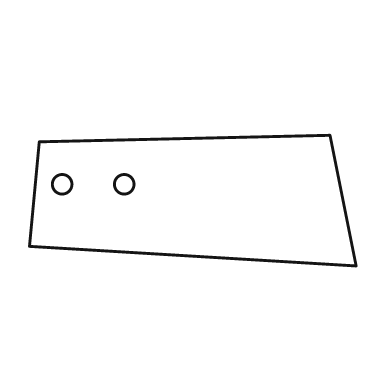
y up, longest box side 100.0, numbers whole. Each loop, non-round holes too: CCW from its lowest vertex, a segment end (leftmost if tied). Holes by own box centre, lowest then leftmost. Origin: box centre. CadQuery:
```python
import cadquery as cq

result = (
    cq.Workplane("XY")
    .moveTo(50.0, -20.0)
    .lineTo(42.0, 20.0)
    .lineTo(-47.0, 18.0)
    .lineTo(-50.0, -14.0)
    .close()
    .moveTo(-40.0, 5.0)
    .circle(3.0)
    .moveTo(-21.0, 5.0)
    .circle(3.0)
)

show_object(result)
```